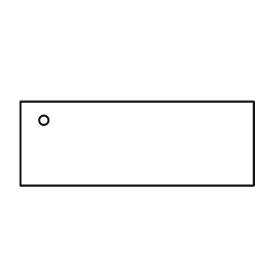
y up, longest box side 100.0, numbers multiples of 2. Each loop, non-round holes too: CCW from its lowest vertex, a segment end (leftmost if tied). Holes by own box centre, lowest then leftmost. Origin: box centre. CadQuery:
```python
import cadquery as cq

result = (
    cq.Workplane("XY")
    .moveTo(-50.0, -18.0)
    .lineTo(50.0, -18.0)
    .lineTo(50.0, 18.0)
    .lineTo(-50.0, 18.0)
    .close()
    .moveTo(-40.0, 10.0)
    .circle(2.0)
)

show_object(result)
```